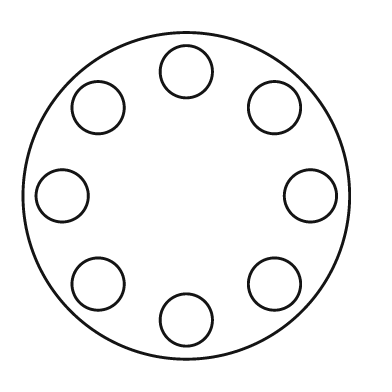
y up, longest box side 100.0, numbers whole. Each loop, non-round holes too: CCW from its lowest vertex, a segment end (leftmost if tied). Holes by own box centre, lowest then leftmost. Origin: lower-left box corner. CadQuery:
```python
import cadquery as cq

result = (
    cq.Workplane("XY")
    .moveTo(50.0, 50.0)
    .circle(50.0)
    .moveTo(50.0, 12.0)
    .circle(8.0)
    .moveTo(23.0, 23.0)
    .circle(8.0)
    .moveTo(77.0, 23.0)
    .circle(8.0)
    .moveTo(12.0, 50.0)
    .circle(8.0)
    .moveTo(88.0, 50.0)
    .circle(8.0)
    .moveTo(23.0, 77.0)
    .circle(8.0)
    .moveTo(77.0, 77.0)
    .circle(8.0)
    .moveTo(50.0, 88.0)
    .circle(8.0)
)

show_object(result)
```